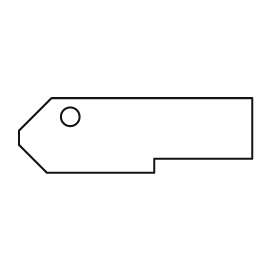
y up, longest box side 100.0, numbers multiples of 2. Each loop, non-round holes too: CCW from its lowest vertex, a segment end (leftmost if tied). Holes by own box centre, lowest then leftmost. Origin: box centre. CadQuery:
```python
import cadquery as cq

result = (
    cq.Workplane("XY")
    .moveTo(-38.0, -16.0)
    .lineTo(8.0, -16.0)
    .lineTo(8.0, -10.0)
    .lineTo(50.0, -10.0)
    .lineTo(50.0, 16.0)
    .lineTo(-36.0, 16.0)
    .lineTo(-50.0, 2.0)
    .lineTo(-50.0, -4.0)
    .close()
    .moveTo(-28.0, 8.0)
    .circle(4.0)
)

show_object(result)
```